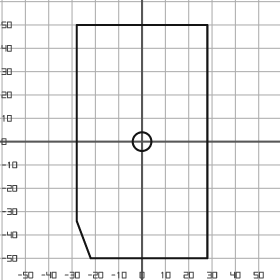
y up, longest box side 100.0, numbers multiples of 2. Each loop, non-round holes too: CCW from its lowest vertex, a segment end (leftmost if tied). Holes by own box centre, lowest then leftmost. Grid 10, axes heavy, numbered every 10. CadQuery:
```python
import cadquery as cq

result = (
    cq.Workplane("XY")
    .moveTo(-22.0, -50.0)
    .lineTo(28.0, -50.0)
    .lineTo(28.0, 50.0)
    .lineTo(-28.0, 50.0)
    .lineTo(-28.0, -34.0)
    .close()
    .moveTo(0.0, 0.0)
    .circle(4.0)
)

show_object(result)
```